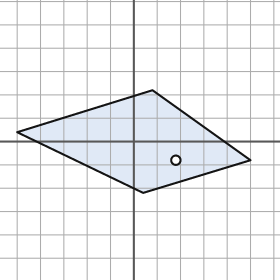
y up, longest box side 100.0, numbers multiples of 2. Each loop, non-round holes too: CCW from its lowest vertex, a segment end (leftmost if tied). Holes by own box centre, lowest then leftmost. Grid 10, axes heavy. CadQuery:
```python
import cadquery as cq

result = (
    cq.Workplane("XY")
    .moveTo(4.0, -22.0)
    .lineTo(50.0, -8.0)
    .lineTo(8.0, 22.0)
    .lineTo(-50.0, 4.0)
    .close()
    .moveTo(18.0, -8.0)
    .circle(2.0)
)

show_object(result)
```